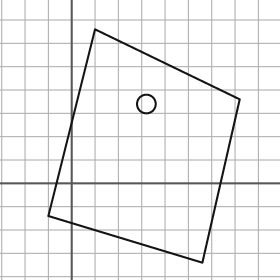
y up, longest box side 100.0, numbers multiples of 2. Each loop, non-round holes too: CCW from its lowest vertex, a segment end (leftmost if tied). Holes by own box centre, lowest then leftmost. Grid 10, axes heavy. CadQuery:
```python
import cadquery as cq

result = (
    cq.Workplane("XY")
    .moveTo(56.0, -34.0)
    .lineTo(72.0, 36.0)
    .lineTo(10.0, 66.0)
    .lineTo(-10.0, -14.0)
    .close()
    .moveTo(32.0, 34.0)
    .circle(4.0)
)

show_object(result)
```